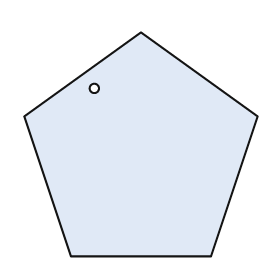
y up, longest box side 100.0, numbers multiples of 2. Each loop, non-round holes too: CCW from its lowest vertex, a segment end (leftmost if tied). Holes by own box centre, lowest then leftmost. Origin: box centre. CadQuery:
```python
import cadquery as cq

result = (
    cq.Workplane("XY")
    .moveTo(-30.0, -48.0)
    .lineTo(30.0, -48.0)
    .lineTo(50.0, 12.0)
    .lineTo(0.0, 48.0)
    .lineTo(-50.0, 12.0)
    .close()
    .moveTo(-20.0, 24.0)
    .circle(2.0)
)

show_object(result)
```